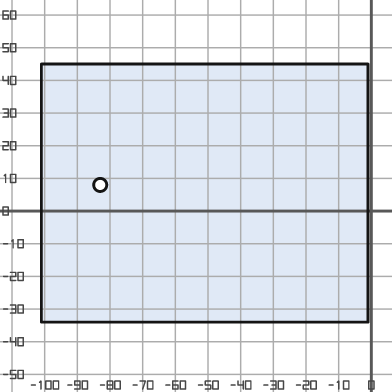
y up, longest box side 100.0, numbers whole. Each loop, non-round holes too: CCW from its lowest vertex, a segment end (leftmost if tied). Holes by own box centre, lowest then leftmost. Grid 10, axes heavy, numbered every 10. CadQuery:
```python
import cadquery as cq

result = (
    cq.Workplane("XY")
    .moveTo(-101.0, -34.0)
    .lineTo(-1.0, -34.0)
    .lineTo(-1.0, 45.0)
    .lineTo(-101.0, 45.0)
    .close()
    .moveTo(-83.0, 8.0)
    .circle(2.0)
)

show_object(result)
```